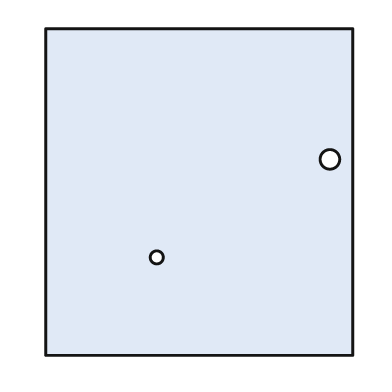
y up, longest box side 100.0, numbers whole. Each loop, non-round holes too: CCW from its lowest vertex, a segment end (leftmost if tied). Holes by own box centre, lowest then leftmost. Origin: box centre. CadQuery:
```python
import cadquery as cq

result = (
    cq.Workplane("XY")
    .moveTo(-47.0, -50.0)
    .lineTo(47.0, -50.0)
    .lineTo(47.0, 50.0)
    .lineTo(-47.0, 50.0)
    .close()
    .moveTo(-13.0, -20.0)
    .circle(2.0)
    .moveTo(40.0, 10.0)
    .circle(3.0)
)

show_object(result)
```